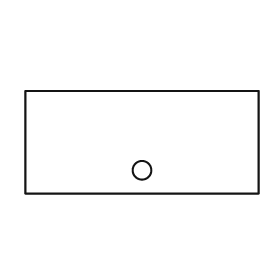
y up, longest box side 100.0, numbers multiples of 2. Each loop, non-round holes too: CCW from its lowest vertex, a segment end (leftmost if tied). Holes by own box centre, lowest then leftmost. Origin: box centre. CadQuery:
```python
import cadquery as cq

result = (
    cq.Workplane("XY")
    .moveTo(-50.0, -22.0)
    .lineTo(50.0, -22.0)
    .lineTo(50.0, 22.0)
    .lineTo(-50.0, 22.0)
    .close()
    .moveTo(0.0, -12.0)
    .circle(4.0)
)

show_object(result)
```